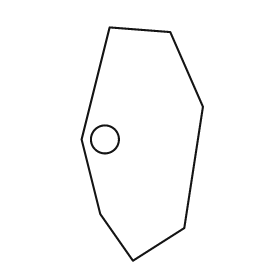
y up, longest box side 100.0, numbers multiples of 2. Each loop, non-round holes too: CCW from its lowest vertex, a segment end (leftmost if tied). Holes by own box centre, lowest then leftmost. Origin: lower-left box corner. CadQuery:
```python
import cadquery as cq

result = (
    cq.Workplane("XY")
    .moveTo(22.0, 0.0)
    .lineTo(44.0, 14.0)
    .lineTo(52.0, 66.0)
    .lineTo(38.0, 98.0)
    .lineTo(12.0, 100.0)
    .lineTo(0.0, 52.0)
    .lineTo(8.0, 20.0)
    .close()
    .moveTo(10.0, 52.0)
    .circle(6.0)
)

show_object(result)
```